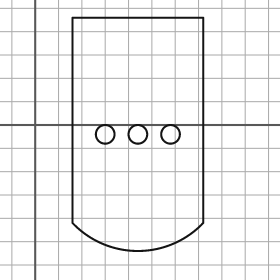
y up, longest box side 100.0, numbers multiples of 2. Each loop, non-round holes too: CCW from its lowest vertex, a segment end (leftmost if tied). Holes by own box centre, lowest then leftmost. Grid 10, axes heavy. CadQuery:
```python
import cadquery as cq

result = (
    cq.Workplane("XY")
    .moveTo(16.0, -42.0)
    .threePointArc((44.0, -54.0), (72.0, -42.0))
    .lineTo(72.0, 46.0)
    .lineTo(16.0, 46.0)
    .close()
    .moveTo(30.0, -4.0)
    .circle(4.0)
    .moveTo(44.0, -4.0)
    .circle(4.0)
    .moveTo(58.0, -4.0)
    .circle(4.0)
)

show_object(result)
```